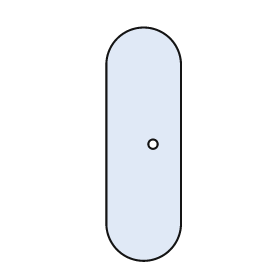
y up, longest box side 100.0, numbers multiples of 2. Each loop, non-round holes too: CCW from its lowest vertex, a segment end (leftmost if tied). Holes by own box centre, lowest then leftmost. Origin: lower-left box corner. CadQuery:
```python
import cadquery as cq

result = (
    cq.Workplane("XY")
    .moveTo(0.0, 16.0)
    .threePointArc((16.0, 0.0), (32.0, 16.0))
    .lineTo(32.0, 84.0)
    .threePointArc((16.0, 100.0), (0.0, 84.0))
    .close()
    .moveTo(20.0, 50.0)
    .circle(2.0)
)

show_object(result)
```